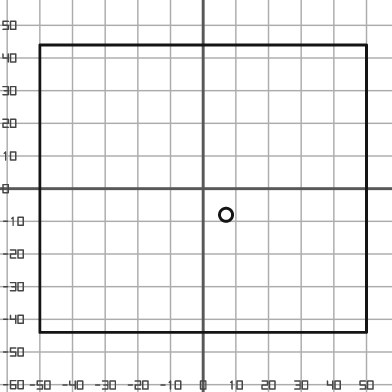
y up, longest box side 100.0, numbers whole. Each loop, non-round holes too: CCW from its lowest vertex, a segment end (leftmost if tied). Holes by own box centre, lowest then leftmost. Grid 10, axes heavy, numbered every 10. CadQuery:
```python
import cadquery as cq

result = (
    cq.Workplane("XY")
    .moveTo(-50.0, -44.0)
    .lineTo(50.0, -44.0)
    .lineTo(50.0, 44.0)
    .lineTo(-50.0, 44.0)
    .close()
    .moveTo(7.0, -8.0)
    .circle(2.0)
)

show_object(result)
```